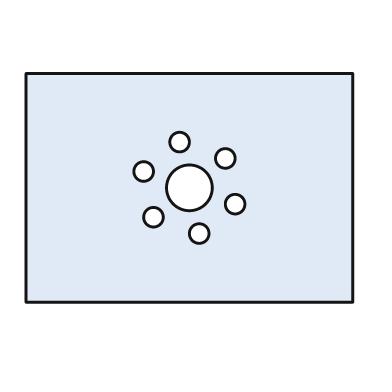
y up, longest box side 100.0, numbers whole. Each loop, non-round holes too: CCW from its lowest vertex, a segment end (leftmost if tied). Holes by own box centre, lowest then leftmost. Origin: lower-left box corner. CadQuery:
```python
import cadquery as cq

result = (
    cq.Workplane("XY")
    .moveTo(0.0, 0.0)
    .lineTo(100.0, 0.0)
    .lineTo(100.0, 70.0)
    .lineTo(0.0, 70.0)
    .close()
    .moveTo(53.0, 21.0)
    .circle(3.0)
    .moveTo(39.0, 26.0)
    .circle(3.0)
    .moveTo(64.0, 30.0)
    .circle(3.0)
    .moveTo(50.0, 35.0)
    .circle(7.0)
    .moveTo(36.0, 40.0)
    .circle(3.0)
    .moveTo(61.0, 44.0)
    .circle(3.0)
    .moveTo(47.0, 49.0)
    .circle(3.0)
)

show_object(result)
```